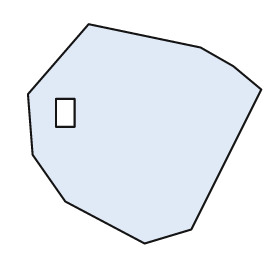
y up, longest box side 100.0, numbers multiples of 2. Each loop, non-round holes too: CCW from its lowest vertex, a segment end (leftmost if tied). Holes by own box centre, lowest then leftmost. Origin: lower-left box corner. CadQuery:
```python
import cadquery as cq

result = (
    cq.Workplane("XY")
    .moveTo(50.0, 0.0)
    .lineTo(70.0, 6.0)
    .lineTo(100.0, 66.0)
    .lineTo(88.0, 76.0)
    .lineTo(74.0, 84.0)
    .lineTo(26.0, 94.0)
    .lineTo(0.0, 64.0)
    .lineTo(2.0, 38.0)
    .lineTo(16.0, 18.0)
    .close()
    .moveTo(12.0, 50.0)
    .lineTo(20.0, 50.0)
    .lineTo(20.0, 62.0)
    .lineTo(12.0, 62.0)
    .close()
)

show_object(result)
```